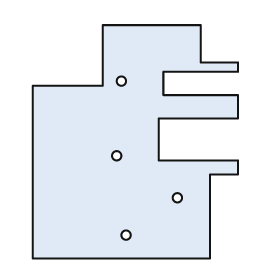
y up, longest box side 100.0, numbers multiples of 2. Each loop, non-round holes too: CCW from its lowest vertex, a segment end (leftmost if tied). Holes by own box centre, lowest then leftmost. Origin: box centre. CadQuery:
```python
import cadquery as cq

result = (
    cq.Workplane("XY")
    .moveTo(-44.0, -50.0)
    .lineTo(32.0, -50.0)
    .lineTo(32.0, -14.0)
    .lineTo(44.0, -14.0)
    .lineTo(44.0, -8.0)
    .lineTo(10.0, -8.0)
    .lineTo(10.0, 10.0)
    .lineTo(44.0, 10.0)
    .lineTo(44.0, 20.0)
    .lineTo(12.0, 20.0)
    .lineTo(12.0, 30.0)
    .lineTo(44.0, 30.0)
    .lineTo(44.0, 34.0)
    .lineTo(28.0, 34.0)
    .lineTo(28.0, 50.0)
    .lineTo(-14.0, 50.0)
    .lineTo(-14.0, 24.0)
    .lineTo(-44.0, 24.0)
    .close()
    .moveTo(-4.0, -40.0)
    .circle(2.0)
    .moveTo(18.0, -24.0)
    .circle(2.0)
    .moveTo(-8.0, -6.0)
    .circle(2.0)
    .moveTo(-6.0, 26.0)
    .circle(2.0)
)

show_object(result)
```